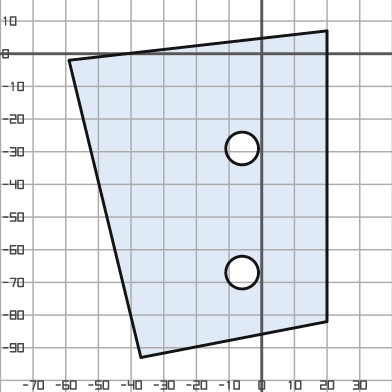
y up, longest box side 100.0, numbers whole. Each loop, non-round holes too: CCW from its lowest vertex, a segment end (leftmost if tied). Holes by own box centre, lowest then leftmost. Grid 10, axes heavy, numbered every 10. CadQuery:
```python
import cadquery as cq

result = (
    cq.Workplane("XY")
    .moveTo(-37.0, -93.0)
    .lineTo(20.0, -82.0)
    .lineTo(20.0, 7.0)
    .lineTo(-59.0, -2.0)
    .close()
    .moveTo(-6.0, -67.0)
    .circle(5.0)
    .moveTo(-6.0, -29.0)
    .circle(5.0)
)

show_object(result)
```